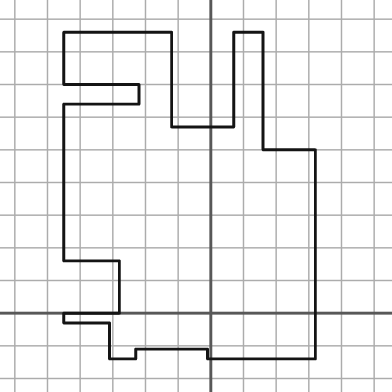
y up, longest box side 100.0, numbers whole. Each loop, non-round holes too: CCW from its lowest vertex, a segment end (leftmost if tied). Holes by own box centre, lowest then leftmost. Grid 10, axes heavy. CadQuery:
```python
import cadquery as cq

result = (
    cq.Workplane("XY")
    .moveTo(-31.0, -14.0)
    .lineTo(-23.0, -14.0)
    .lineTo(-23.0, -11.0)
    .lineTo(-1.0, -11.0)
    .lineTo(-1.0, -14.0)
    .lineTo(32.0, -14.0)
    .lineTo(32.0, 50.0)
    .lineTo(16.0, 50.0)
    .lineTo(16.0, 86.0)
    .lineTo(7.0, 86.0)
    .lineTo(7.0, 57.0)
    .lineTo(-12.0, 57.0)
    .lineTo(-12.0, 86.0)
    .lineTo(-45.0, 86.0)
    .lineTo(-45.0, 70.0)
    .lineTo(-22.0, 70.0)
    .lineTo(-22.0, 64.0)
    .lineTo(-45.0, 64.0)
    .lineTo(-45.0, 16.0)
    .lineTo(-28.0, 16.0)
    .lineTo(-28.0, 0.0)
    .lineTo(-45.0, 0.0)
    .lineTo(-45.0, -3.0)
    .lineTo(-31.0, -3.0)
    .close()
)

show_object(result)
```